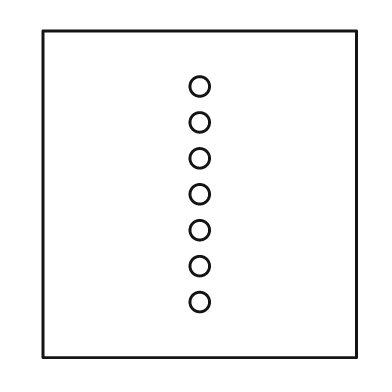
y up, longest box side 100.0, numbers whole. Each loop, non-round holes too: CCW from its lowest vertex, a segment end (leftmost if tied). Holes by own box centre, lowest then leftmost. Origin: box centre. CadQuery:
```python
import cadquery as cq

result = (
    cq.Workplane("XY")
    .moveTo(-48.0, -50.0)
    .lineTo(48.0, -50.0)
    .lineTo(48.0, 50.0)
    .lineTo(-48.0, 50.0)
    .close()
    .moveTo(0.0, -33.0)
    .circle(3.0)
    .moveTo(0.0, -22.0)
    .circle(3.0)
    .moveTo(0.0, -11.0)
    .circle(3.0)
    .moveTo(0.0, 0.0)
    .circle(3.0)
    .moveTo(0.0, 11.0)
    .circle(3.0)
    .moveTo(0.0, 22.0)
    .circle(3.0)
    .moveTo(0.0, 33.0)
    .circle(3.0)
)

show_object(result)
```